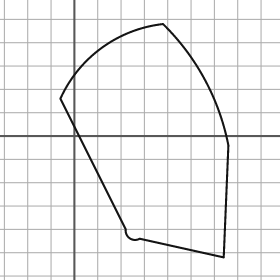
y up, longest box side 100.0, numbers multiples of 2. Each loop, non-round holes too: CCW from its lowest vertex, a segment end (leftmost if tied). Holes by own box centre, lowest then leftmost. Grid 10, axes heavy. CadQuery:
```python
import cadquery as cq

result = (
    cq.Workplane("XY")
    .moveTo(64.0, -52.0)
    .lineTo(66.0, -4.0)
    .threePointArc((56.0, 24.0), (38.0, 48.0))
    .threePointArc((12.0, 38.0), (-6.0, 16.0))
    .lineTo(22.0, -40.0)
    .threePointArc((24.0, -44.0), (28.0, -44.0))
    .close()
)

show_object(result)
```